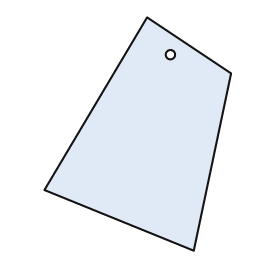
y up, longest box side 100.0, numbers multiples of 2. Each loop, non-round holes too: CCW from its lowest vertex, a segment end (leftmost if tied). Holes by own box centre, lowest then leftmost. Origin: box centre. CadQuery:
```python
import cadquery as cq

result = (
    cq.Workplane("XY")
    .moveTo(24.0, -50.0)
    .lineTo(40.0, 26.0)
    .lineTo(4.0, 50.0)
    .lineTo(-40.0, -24.0)
    .close()
    .moveTo(14.0, 34.0)
    .circle(2.0)
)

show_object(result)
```